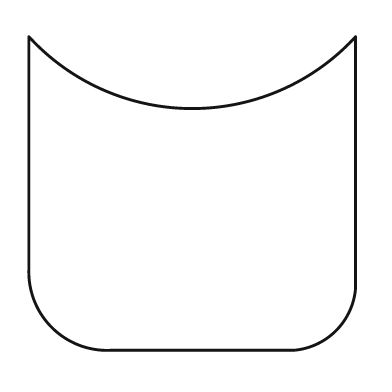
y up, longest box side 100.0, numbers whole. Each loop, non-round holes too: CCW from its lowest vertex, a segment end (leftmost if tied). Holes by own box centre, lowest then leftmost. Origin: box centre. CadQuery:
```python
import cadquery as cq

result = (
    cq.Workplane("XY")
    .moveTo(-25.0, -48.0)
    .lineTo(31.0, -48.0)
    .threePointArc((44.0, -42.0), (50.0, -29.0))
    .lineTo(50.0, 48.0)
    .threePointArc((0.0, 26.0), (-50.0, 48.0))
    .lineTo(-50.0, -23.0)
    .threePointArc((-43.0, -41.0), (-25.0, -48.0))
    .close()
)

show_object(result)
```